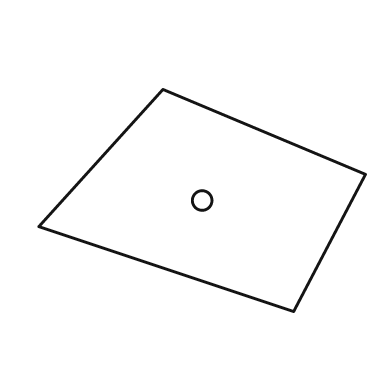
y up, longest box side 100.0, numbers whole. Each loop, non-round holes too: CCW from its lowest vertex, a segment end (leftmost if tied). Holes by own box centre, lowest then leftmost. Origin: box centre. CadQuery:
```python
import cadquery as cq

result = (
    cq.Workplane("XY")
    .moveTo(28.0, -34.0)
    .lineTo(50.0, 8.0)
    .lineTo(-12.0, 34.0)
    .lineTo(-50.0, -8.0)
    .close()
    .moveTo(0.0, 0.0)
    .circle(3.0)
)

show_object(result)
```